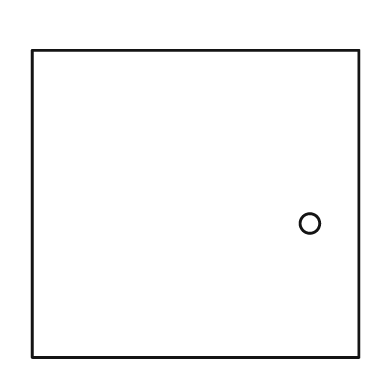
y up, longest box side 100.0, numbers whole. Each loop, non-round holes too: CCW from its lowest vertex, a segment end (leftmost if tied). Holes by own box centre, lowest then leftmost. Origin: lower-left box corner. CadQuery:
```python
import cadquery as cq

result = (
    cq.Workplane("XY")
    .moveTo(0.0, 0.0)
    .lineTo(100.0, 0.0)
    .lineTo(100.0, 94.0)
    .lineTo(0.0, 94.0)
    .close()
    .moveTo(85.0, 41.0)
    .circle(3.0)
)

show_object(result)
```